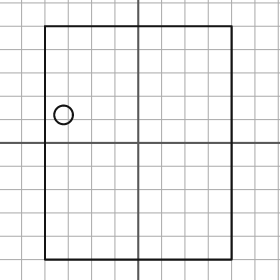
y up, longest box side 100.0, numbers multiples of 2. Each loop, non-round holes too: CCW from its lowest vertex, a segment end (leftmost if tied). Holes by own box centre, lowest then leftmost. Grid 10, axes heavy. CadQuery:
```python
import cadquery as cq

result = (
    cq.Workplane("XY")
    .moveTo(-40.0, -50.0)
    .lineTo(40.0, -50.0)
    .lineTo(40.0, 50.0)
    .lineTo(-40.0, 50.0)
    .close()
    .moveTo(-32.0, 12.0)
    .circle(4.0)
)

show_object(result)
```